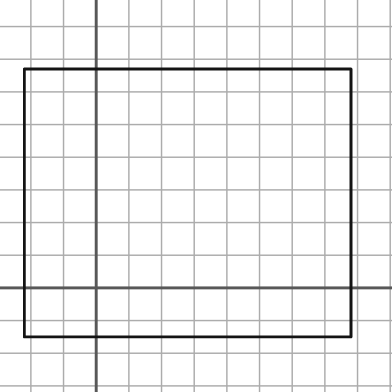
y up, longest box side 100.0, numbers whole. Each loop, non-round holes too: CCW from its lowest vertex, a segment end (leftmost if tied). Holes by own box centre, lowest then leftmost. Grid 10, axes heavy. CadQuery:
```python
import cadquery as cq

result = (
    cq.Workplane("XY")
    .moveTo(-22.0, -15.0)
    .lineTo(78.0, -15.0)
    .lineTo(78.0, 67.0)
    .lineTo(-22.0, 67.0)
    .close()
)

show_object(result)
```